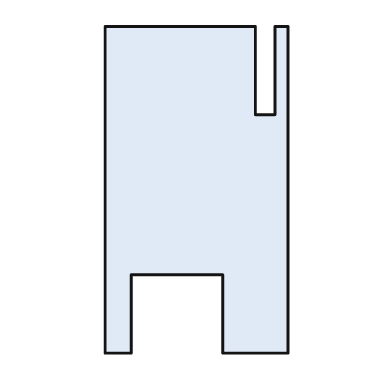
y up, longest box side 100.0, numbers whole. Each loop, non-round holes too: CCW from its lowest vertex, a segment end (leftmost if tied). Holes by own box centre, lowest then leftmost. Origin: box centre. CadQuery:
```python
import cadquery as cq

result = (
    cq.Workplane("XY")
    .moveTo(-28.0, -50.0)
    .lineTo(-20.0, -50.0)
    .lineTo(-20.0, -26.0)
    .lineTo(8.0, -26.0)
    .lineTo(8.0, -50.0)
    .lineTo(28.0, -50.0)
    .lineTo(28.0, 50.0)
    .lineTo(24.0, 50.0)
    .lineTo(24.0, 23.0)
    .lineTo(18.0, 23.0)
    .lineTo(18.0, 50.0)
    .lineTo(-28.0, 50.0)
    .close()
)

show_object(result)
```